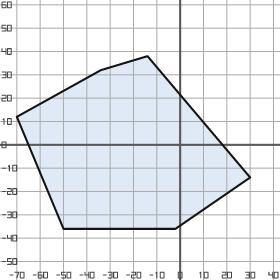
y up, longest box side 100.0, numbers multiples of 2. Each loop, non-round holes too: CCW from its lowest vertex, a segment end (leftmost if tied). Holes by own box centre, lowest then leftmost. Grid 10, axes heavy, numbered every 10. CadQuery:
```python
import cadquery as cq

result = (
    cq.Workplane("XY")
    .moveTo(-50.0, -36.0)
    .lineTo(-2.0, -36.0)
    .lineTo(30.0, -14.0)
    .lineTo(-14.0, 38.0)
    .lineTo(-34.0, 32.0)
    .lineTo(-70.0, 12.0)
    .close()
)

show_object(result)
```